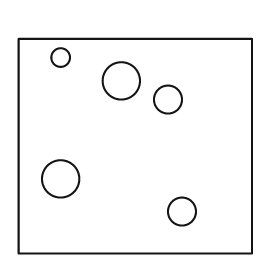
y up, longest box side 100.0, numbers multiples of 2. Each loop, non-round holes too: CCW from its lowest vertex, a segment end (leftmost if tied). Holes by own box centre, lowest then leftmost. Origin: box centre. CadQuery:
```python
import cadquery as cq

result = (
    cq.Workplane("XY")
    .moveTo(-50.0, -46.0)
    .lineTo(50.0, -46.0)
    .lineTo(50.0, 46.0)
    .lineTo(-50.0, 46.0)
    .close()
    .moveTo(20.0, -28.0)
    .circle(6.0)
    .moveTo(-32.0, -14.0)
    .circle(8.0)
    .moveTo(14.0, 20.0)
    .circle(6.0)
    .moveTo(-6.0, 28.0)
    .circle(8.0)
    .moveTo(-32.0, 38.0)
    .circle(4.0)
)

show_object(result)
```